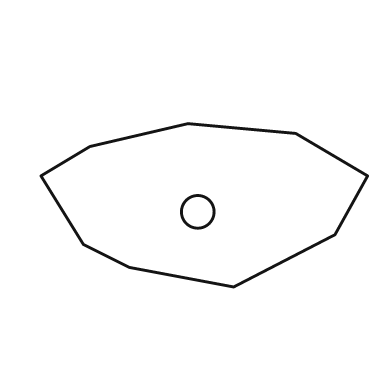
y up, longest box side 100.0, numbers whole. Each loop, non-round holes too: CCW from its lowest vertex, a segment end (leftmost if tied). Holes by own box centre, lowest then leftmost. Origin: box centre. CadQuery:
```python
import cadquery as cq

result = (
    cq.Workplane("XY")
    .moveTo(9.0, -25.0)
    .lineTo(40.0, -9.0)
    .lineTo(50.0, 9.0)
    .lineTo(28.0, 22.0)
    .lineTo(-5.0, 25.0)
    .lineTo(-35.0, 18.0)
    .lineTo(-50.0, 9.0)
    .lineTo(-37.0, -12.0)
    .lineTo(-23.0, -19.0)
    .close()
    .moveTo(-2.0, -2.0)
    .circle(5.0)
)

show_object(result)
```